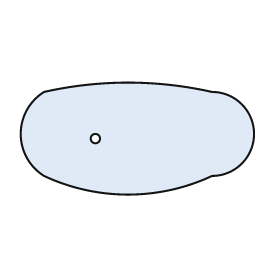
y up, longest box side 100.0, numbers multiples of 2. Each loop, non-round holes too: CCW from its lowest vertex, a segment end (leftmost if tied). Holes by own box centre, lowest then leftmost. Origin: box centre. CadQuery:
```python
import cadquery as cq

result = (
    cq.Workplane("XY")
    .moveTo(-40.0, -16.0)
    .threePointArc((-4.0, -24.0), (32.0, -16.0))
    .threePointArc((50.0, 2.0), (32.0, 20.0))
    .threePointArc((-4.0, 24.0), (-40.0, 20.0))
    .threePointArc((-50.0, 2.0), (-40.0, -16.0))
    .close()
    .moveTo(-18.0, 0.0)
    .circle(2.0)
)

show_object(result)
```